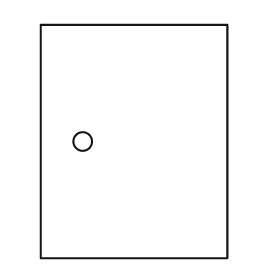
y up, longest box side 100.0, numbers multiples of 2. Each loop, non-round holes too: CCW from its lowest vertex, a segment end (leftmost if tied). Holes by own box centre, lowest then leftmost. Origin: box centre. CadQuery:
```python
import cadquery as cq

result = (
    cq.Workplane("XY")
    .moveTo(-40.0, -50.0)
    .lineTo(40.0, -50.0)
    .lineTo(40.0, 50.0)
    .lineTo(-40.0, 50.0)
    .close()
    .moveTo(-22.0, 0.0)
    .circle(4.0)
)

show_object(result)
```